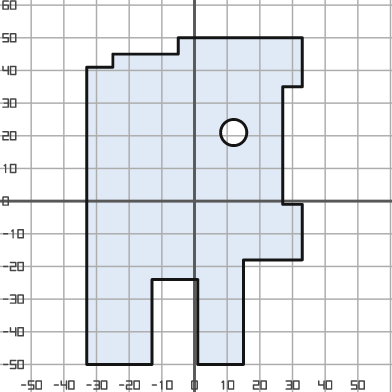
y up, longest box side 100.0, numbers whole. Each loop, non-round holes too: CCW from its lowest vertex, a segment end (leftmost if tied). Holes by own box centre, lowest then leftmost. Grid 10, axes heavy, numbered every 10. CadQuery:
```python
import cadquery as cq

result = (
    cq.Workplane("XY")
    .moveTo(-33.0, -50.0)
    .lineTo(-13.0, -50.0)
    .lineTo(-13.0, -24.0)
    .lineTo(1.0, -24.0)
    .lineTo(1.0, -50.0)
    .lineTo(15.0, -50.0)
    .lineTo(15.0, -18.0)
    .lineTo(33.0, -18.0)
    .lineTo(33.0, -1.0)
    .lineTo(27.0, -1.0)
    .lineTo(27.0, 35.0)
    .lineTo(33.0, 35.0)
    .lineTo(33.0, 50.0)
    .lineTo(-5.0, 50.0)
    .lineTo(-5.0, 45.0)
    .lineTo(-25.0, 45.0)
    .lineTo(-25.0, 41.0)
    .lineTo(-33.0, 41.0)
    .close()
    .moveTo(12.0, 21.0)
    .circle(4.0)
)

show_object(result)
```